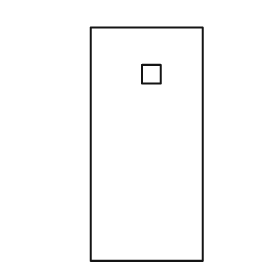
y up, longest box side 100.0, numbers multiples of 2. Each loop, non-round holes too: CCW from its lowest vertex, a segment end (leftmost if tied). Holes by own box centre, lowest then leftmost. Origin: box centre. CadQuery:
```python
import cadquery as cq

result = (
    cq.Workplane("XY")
    .moveTo(-24.0, -50.0)
    .lineTo(24.0, -50.0)
    .lineTo(24.0, 50.0)
    .lineTo(-24.0, 50.0)
    .close()
    .moveTo(-2.0, 26.0)
    .lineTo(6.0, 26.0)
    .lineTo(6.0, 34.0)
    .lineTo(-2.0, 34.0)
    .close()
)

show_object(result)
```